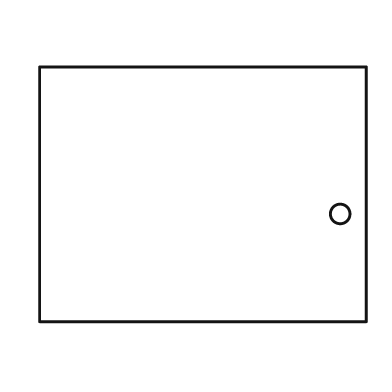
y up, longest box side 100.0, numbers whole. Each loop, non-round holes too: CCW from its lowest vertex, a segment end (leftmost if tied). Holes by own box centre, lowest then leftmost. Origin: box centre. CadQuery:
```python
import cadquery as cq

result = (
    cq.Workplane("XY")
    .moveTo(-50.0, -39.0)
    .lineTo(50.0, -39.0)
    .lineTo(50.0, 39.0)
    .lineTo(-50.0, 39.0)
    .close()
    .moveTo(42.0, -6.0)
    .circle(3.0)
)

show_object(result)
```